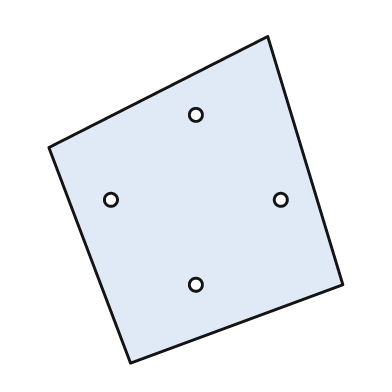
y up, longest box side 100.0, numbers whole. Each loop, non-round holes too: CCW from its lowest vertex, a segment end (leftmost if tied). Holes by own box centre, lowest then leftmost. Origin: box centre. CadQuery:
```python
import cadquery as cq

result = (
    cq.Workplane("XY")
    .moveTo(-20.0, -50.0)
    .lineTo(45.0, -26.0)
    .lineTo(22.0, 50.0)
    .lineTo(-45.0, 16.0)
    .close()
    .moveTo(0.0, -26.0)
    .circle(2.0)
    .moveTo(-26.0, 0.0)
    .circle(2.0)
    .moveTo(26.0, 0.0)
    .circle(2.0)
    .moveTo(0.0, 26.0)
    .circle(2.0)
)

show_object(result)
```